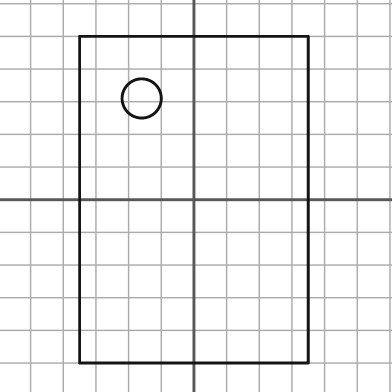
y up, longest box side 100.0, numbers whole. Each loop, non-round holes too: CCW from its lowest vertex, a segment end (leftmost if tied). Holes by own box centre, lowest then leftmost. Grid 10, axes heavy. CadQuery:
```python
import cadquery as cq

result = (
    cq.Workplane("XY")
    .moveTo(-35.0, -50.0)
    .lineTo(35.0, -50.0)
    .lineTo(35.0, 50.0)
    .lineTo(-35.0, 50.0)
    .close()
    .moveTo(-16.0, 31.0)
    .circle(6.0)
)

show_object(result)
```